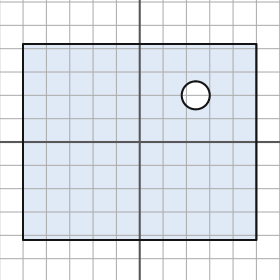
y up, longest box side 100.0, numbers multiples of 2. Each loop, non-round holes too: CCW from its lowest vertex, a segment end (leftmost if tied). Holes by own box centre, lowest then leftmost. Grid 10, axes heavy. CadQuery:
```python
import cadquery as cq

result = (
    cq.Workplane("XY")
    .moveTo(-50.0, -42.0)
    .lineTo(50.0, -42.0)
    .lineTo(50.0, 42.0)
    .lineTo(-50.0, 42.0)
    .close()
    .moveTo(24.0, 20.0)
    .circle(6.0)
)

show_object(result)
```